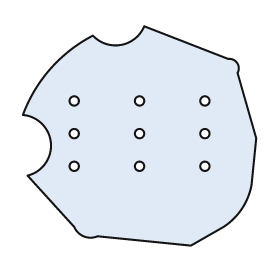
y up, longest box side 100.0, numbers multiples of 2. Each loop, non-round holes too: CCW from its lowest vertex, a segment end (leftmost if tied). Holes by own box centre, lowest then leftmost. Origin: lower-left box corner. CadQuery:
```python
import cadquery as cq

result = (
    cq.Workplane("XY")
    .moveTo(72.0, 0.0)
    .lineTo(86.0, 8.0)
    .threePointArc((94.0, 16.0), (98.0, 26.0))
    .lineTo(100.0, 46.0)
    .lineTo(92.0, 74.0)
    .threePointArc((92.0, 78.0), (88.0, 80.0))
    .lineTo(52.0, 94.0)
    .threePointArc((42.0, 86.0), (30.0, 90.0))
    .threePointArc((12.0, 76.0), (0.0, 56.0))
    .threePointArc((12.0, 44.0), (2.0, 30.0))
    .lineTo(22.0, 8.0)
    .threePointArc((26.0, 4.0), (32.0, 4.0))
    .close()
    .moveTo(22.0, 34.0)
    .circle(2.0)
    .moveTo(50.0, 34.0)
    .circle(2.0)
    .moveTo(78.0, 34.0)
    .circle(2.0)
    .moveTo(22.0, 48.0)
    .circle(2.0)
    .moveTo(50.0, 48.0)
    .circle(2.0)
    .moveTo(78.0, 48.0)
    .circle(2.0)
    .moveTo(22.0, 62.0)
    .circle(2.0)
    .moveTo(50.0, 62.0)
    .circle(2.0)
    .moveTo(78.0, 62.0)
    .circle(2.0)
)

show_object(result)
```